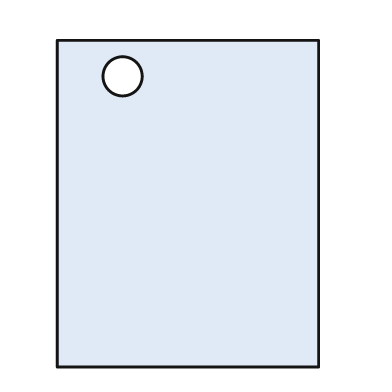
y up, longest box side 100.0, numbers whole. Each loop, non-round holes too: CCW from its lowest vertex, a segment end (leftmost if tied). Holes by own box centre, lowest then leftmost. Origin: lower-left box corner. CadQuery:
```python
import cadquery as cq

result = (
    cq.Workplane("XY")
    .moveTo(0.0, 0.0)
    .lineTo(80.0, 0.0)
    .lineTo(80.0, 100.0)
    .lineTo(0.0, 100.0)
    .close()
    .moveTo(20.0, 89.0)
    .circle(6.0)
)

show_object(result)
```